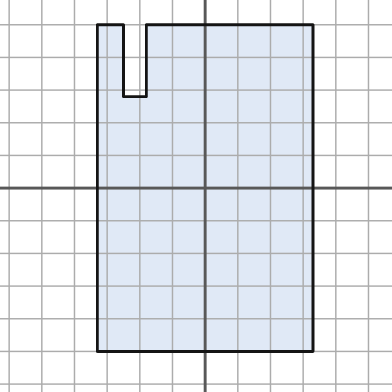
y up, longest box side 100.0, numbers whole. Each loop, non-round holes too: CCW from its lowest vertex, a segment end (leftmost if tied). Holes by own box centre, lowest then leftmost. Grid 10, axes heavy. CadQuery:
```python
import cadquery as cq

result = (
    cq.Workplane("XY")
    .moveTo(-33.0, -50.0)
    .lineTo(33.0, -50.0)
    .lineTo(33.0, 50.0)
    .lineTo(-18.0, 50.0)
    .lineTo(-18.0, 28.0)
    .lineTo(-25.0, 28.0)
    .lineTo(-25.0, 50.0)
    .lineTo(-33.0, 50.0)
    .close()
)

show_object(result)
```